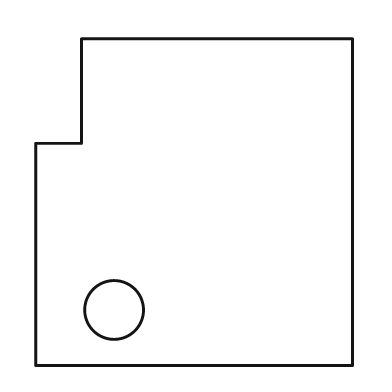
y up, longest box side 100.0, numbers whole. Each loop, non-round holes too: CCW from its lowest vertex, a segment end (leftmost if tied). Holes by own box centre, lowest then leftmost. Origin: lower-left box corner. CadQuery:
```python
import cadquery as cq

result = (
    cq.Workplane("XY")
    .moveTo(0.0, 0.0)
    .lineTo(97.0, 0.0)
    .lineTo(97.0, 100.0)
    .lineTo(14.0, 100.0)
    .lineTo(14.0, 68.0)
    .lineTo(0.0, 68.0)
    .close()
    .moveTo(24.0, 17.0)
    .circle(9.0)
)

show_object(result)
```